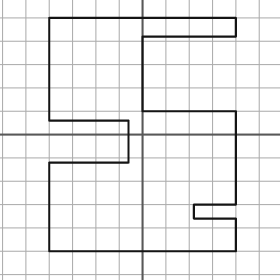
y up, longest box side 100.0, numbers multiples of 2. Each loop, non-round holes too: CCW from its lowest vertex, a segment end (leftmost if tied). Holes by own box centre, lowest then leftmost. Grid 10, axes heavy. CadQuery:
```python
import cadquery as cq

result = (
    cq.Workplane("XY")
    .moveTo(-40.0, -50.0)
    .lineTo(40.0, -50.0)
    .lineTo(40.0, -36.0)
    .lineTo(22.0, -36.0)
    .lineTo(22.0, -30.0)
    .lineTo(40.0, -30.0)
    .lineTo(40.0, 10.0)
    .lineTo(0.0, 10.0)
    .lineTo(0.0, 42.0)
    .lineTo(40.0, 42.0)
    .lineTo(40.0, 50.0)
    .lineTo(-40.0, 50.0)
    .lineTo(-40.0, 6.0)
    .lineTo(-6.0, 6.0)
    .lineTo(-6.0, -12.0)
    .lineTo(-40.0, -12.0)
    .close()
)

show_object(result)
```